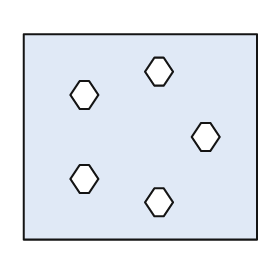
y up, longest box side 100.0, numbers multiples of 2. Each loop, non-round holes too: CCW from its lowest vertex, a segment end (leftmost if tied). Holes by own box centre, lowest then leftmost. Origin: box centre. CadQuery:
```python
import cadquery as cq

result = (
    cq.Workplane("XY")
    .moveTo(-50.0, -44.0)
    .lineTo(50.0, -44.0)
    .lineTo(50.0, 44.0)
    .lineTo(-50.0, 44.0)
    .close()
    .moveTo(6.0, -34.0)
    .lineTo(10.0, -34.0)
    .lineTo(14.0, -28.0)
    .lineTo(10.0, -22.0)
    .lineTo(6.0, -22.0)
    .lineTo(2.0, -28.0)
    .close()
    .moveTo(-26.0, -24.0)
    .lineTo(-22.0, -24.0)
    .lineTo(-18.0, -18.0)
    .lineTo(-22.0, -12.0)
    .lineTo(-26.0, -12.0)
    .lineTo(-30.0, -18.0)
    .close()
    .moveTo(26.0, -6.0)
    .lineTo(30.0, -6.0)
    .lineTo(34.0, 0.0)
    .lineTo(30.0, 6.0)
    .lineTo(26.0, 6.0)
    .lineTo(22.0, 0.0)
    .close()
    .moveTo(-26.0, 12.0)
    .lineTo(-22.0, 12.0)
    .lineTo(-18.0, 18.0)
    .lineTo(-22.0, 24.0)
    .lineTo(-26.0, 24.0)
    .lineTo(-30.0, 18.0)
    .close()
    .moveTo(6.0, 22.0)
    .lineTo(10.0, 22.0)
    .lineTo(14.0, 28.0)
    .lineTo(10.0, 34.0)
    .lineTo(6.0, 34.0)
    .lineTo(2.0, 28.0)
    .close()
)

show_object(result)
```